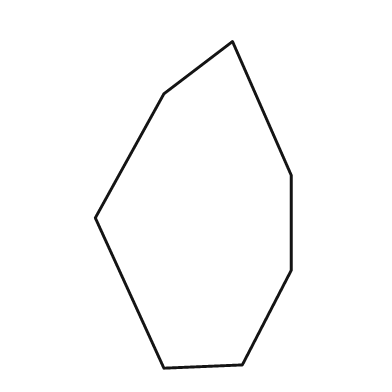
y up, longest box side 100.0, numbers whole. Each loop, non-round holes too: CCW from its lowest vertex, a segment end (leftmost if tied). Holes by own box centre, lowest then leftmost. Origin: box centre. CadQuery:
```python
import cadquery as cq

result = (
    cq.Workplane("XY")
    .moveTo(-9.0, -50.0)
    .lineTo(15.0, -49.0)
    .lineTo(30.0, -20.0)
    .lineTo(30.0, 9.0)
    .lineTo(12.0, 50.0)
    .lineTo(-9.0, 34.0)
    .lineTo(-30.0, -4.0)
    .close()
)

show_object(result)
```